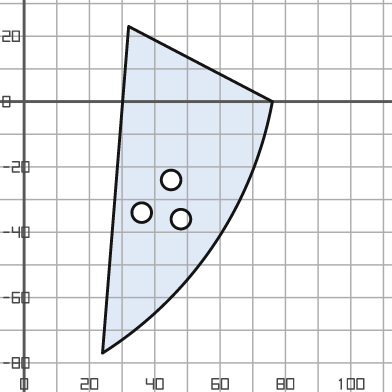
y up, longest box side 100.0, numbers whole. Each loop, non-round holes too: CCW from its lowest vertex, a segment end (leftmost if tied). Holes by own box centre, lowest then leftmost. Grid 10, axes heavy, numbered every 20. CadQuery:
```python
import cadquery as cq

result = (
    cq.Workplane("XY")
    .moveTo(24.0, -77.0)
    .threePointArc((58.0, -44.0), (76.0, 0.0))
    .lineTo(32.0, 23.0)
    .close()
    .moveTo(48.0, -36.0)
    .circle(3.0)
    .moveTo(36.0, -34.0)
    .circle(3.0)
    .moveTo(45.0, -24.0)
    .circle(3.0)
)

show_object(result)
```